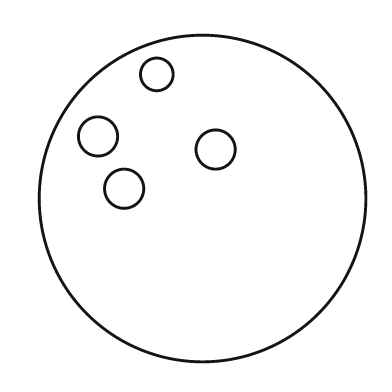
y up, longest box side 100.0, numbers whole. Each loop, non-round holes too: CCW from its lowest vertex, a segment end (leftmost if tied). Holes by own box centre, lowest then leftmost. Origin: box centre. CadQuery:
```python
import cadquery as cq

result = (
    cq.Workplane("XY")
    .moveTo(0.0, 0.0)
    .circle(50.0)
    .moveTo(-24.0, 3.0)
    .circle(6.0)
    .moveTo(4.0, 15.0)
    .circle(6.0)
    .moveTo(-32.0, 19.0)
    .circle(6.0)
    .moveTo(-14.0, 38.0)
    .circle(5.0)
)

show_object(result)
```